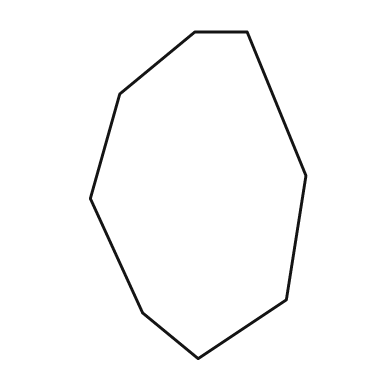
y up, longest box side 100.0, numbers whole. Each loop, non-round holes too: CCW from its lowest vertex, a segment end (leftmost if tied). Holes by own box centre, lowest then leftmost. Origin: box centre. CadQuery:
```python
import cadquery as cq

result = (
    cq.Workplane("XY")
    .moveTo(0.0, -50.0)
    .lineTo(27.0, -32.0)
    .lineTo(33.0, 6.0)
    .lineTo(15.0, 50.0)
    .lineTo(-1.0, 50.0)
    .lineTo(-24.0, 31.0)
    .lineTo(-33.0, -1.0)
    .lineTo(-17.0, -36.0)
    .close()
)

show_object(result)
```